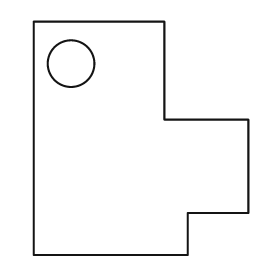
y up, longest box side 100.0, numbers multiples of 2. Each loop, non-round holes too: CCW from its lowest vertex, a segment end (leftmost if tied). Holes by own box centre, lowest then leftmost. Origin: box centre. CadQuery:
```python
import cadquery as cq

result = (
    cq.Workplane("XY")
    .moveTo(-46.0, -50.0)
    .lineTo(20.0, -50.0)
    .lineTo(20.0, -32.0)
    .lineTo(46.0, -32.0)
    .lineTo(46.0, 8.0)
    .lineTo(10.0, 8.0)
    .lineTo(10.0, 50.0)
    .lineTo(-46.0, 50.0)
    .close()
    .moveTo(-30.0, 32.0)
    .circle(10.0)
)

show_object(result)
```